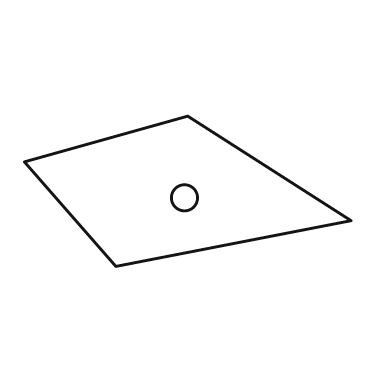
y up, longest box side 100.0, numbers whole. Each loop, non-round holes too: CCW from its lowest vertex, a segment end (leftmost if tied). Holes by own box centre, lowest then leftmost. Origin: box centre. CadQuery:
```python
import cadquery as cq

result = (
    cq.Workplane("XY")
    .moveTo(-22.0, -23.0)
    .lineTo(50.0, -9.0)
    .lineTo(0.0, 23.0)
    .lineTo(-50.0, 9.0)
    .close()
    .moveTo(-1.0, -2.0)
    .circle(4.0)
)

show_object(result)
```